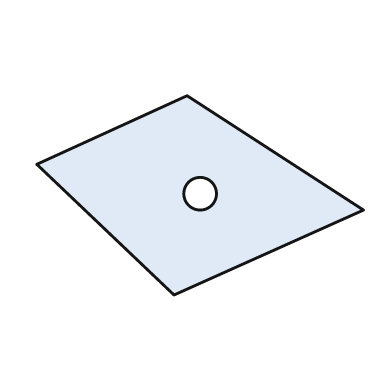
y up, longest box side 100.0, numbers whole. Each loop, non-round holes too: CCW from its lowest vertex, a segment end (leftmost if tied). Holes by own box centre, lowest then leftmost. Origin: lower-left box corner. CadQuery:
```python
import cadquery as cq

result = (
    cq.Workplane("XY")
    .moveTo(42.0, 0.0)
    .lineTo(100.0, 26.0)
    .lineTo(46.0, 61.0)
    .lineTo(0.0, 40.0)
    .close()
    .moveTo(50.0, 31.0)
    .circle(5.0)
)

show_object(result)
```